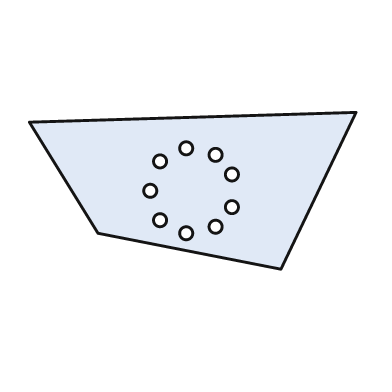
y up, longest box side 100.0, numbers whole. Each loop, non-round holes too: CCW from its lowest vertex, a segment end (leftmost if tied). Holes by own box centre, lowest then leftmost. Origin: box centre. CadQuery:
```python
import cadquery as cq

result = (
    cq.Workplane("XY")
    .moveTo(27.0, -24.0)
    .lineTo(50.0, 24.0)
    .lineTo(-50.0, 21.0)
    .lineTo(-29.0, -13.0)
    .close()
    .moveTo(-2.0, -13.0)
    .circle(2.0)
    .moveTo(7.0, -11.0)
    .circle(2.0)
    .moveTo(-10.0, -9.0)
    .circle(2.0)
    .moveTo(12.0, -5.0)
    .circle(2.0)
    .moveTo(-13.0, 0.0)
    .circle(2.0)
    .moveTo(12.0, 5.0)
    .circle(2.0)
    .moveTo(-10.0, 9.0)
    .circle(2.0)
    .moveTo(7.0, 11.0)
    .circle(2.0)
    .moveTo(-2.0, 13.0)
    .circle(2.0)
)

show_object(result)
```